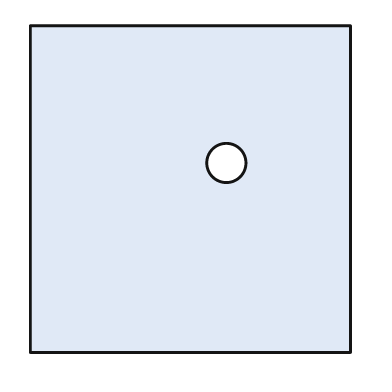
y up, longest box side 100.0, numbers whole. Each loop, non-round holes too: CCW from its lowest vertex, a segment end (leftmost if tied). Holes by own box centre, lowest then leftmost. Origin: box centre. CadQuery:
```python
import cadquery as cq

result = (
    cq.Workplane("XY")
    .moveTo(-49.0, -50.0)
    .lineTo(49.0, -50.0)
    .lineTo(49.0, 50.0)
    .lineTo(-49.0, 50.0)
    .close()
    .moveTo(11.0, 8.0)
    .circle(6.0)
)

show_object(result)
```